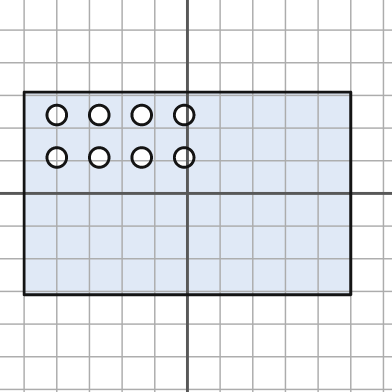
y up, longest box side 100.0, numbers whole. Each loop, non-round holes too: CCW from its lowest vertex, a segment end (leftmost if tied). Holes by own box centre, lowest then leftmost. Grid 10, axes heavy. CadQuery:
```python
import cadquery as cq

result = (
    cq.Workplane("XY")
    .moveTo(-50.0, -31.0)
    .lineTo(50.0, -31.0)
    .lineTo(50.0, 31.0)
    .lineTo(-50.0, 31.0)
    .close()
    .moveTo(-40.0, 11.0)
    .circle(3.0)
    .moveTo(-27.0, 11.0)
    .circle(3.0)
    .moveTo(-14.0, 11.0)
    .circle(3.0)
    .moveTo(-1.0, 11.0)
    .circle(3.0)
    .moveTo(-40.0, 24.0)
    .circle(3.0)
    .moveTo(-27.0, 24.0)
    .circle(3.0)
    .moveTo(-14.0, 24.0)
    .circle(3.0)
    .moveTo(-1.0, 24.0)
    .circle(3.0)
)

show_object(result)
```